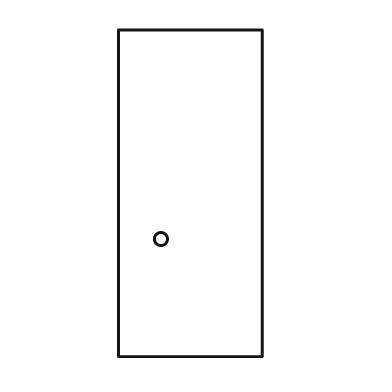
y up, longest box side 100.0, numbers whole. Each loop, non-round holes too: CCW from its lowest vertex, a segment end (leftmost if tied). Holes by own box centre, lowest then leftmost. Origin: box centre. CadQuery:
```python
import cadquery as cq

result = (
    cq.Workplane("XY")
    .moveTo(-22.0, -50.0)
    .lineTo(22.0, -50.0)
    .lineTo(22.0, 50.0)
    .lineTo(-22.0, 50.0)
    .close()
    .moveTo(-9.0, -14.0)
    .circle(2.0)
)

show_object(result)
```